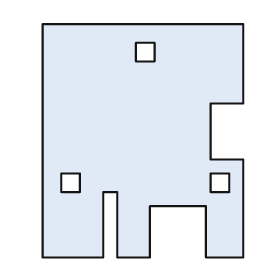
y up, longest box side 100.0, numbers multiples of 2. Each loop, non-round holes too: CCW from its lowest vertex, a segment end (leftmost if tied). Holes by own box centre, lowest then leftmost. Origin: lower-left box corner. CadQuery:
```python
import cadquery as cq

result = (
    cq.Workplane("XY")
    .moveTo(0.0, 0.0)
    .lineTo(26.0, 0.0)
    .lineTo(26.0, 28.0)
    .lineTo(32.0, 28.0)
    .lineTo(32.0, 0.0)
    .lineTo(46.0, 0.0)
    .lineTo(46.0, 22.0)
    .lineTo(70.0, 22.0)
    .lineTo(70.0, 0.0)
    .lineTo(86.0, 0.0)
    .lineTo(86.0, 42.0)
    .lineTo(72.0, 42.0)
    .lineTo(72.0, 66.0)
    .lineTo(86.0, 66.0)
    .lineTo(86.0, 100.0)
    .lineTo(0.0, 100.0)
    .close()
    .moveTo(8.0, 28.0)
    .lineTo(16.0, 28.0)
    .lineTo(16.0, 36.0)
    .lineTo(8.0, 36.0)
    .close()
    .moveTo(72.0, 28.0)
    .lineTo(80.0, 28.0)
    .lineTo(80.0, 36.0)
    .lineTo(72.0, 36.0)
    .close()
    .moveTo(40.0, 84.0)
    .lineTo(48.0, 84.0)
    .lineTo(48.0, 92.0)
    .lineTo(40.0, 92.0)
    .close()
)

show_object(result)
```